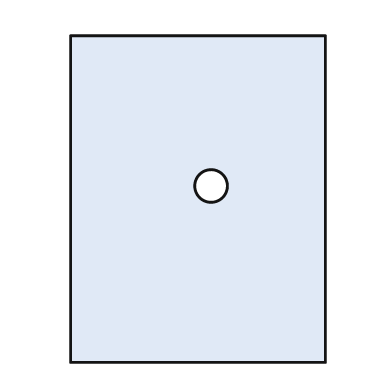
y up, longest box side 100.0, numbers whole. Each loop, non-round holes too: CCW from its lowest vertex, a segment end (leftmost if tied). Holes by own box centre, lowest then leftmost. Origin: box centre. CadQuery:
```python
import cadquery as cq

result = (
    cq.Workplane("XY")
    .moveTo(-39.0, -50.0)
    .lineTo(39.0, -50.0)
    .lineTo(39.0, 50.0)
    .lineTo(-39.0, 50.0)
    .close()
    .moveTo(4.0, 4.0)
    .circle(5.0)
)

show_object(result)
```